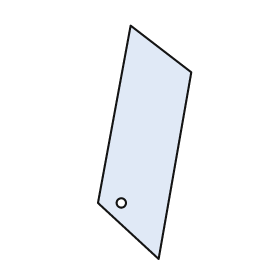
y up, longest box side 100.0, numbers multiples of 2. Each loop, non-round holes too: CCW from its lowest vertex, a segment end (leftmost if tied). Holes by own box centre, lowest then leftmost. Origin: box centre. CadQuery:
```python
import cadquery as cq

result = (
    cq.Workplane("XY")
    .moveTo(6.0, -50.0)
    .lineTo(20.0, 30.0)
    .lineTo(-6.0, 50.0)
    .lineTo(-20.0, -26.0)
    .close()
    .moveTo(-10.0, -26.0)
    .circle(2.0)
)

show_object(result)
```